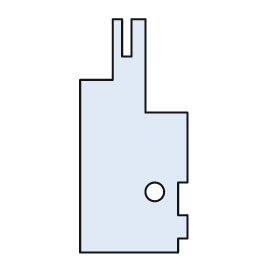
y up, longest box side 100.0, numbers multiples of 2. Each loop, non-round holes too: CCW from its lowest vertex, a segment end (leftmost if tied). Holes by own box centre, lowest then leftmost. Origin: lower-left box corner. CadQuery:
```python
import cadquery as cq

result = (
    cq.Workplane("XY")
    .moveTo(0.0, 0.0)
    .lineTo(42.0, 0.0)
    .lineTo(42.0, 6.0)
    .lineTo(46.0, 6.0)
    .lineTo(46.0, 16.0)
    .lineTo(42.0, 16.0)
    .lineTo(42.0, 30.0)
    .lineTo(46.0, 30.0)
    .lineTo(46.0, 60.0)
    .lineTo(28.0, 60.0)
    .lineTo(28.0, 100.0)
    .lineTo(22.0, 100.0)
    .lineTo(22.0, 84.0)
    .lineTo(18.0, 84.0)
    .lineTo(18.0, 100.0)
    .lineTo(14.0, 100.0)
    .lineTo(14.0, 74.0)
    .lineTo(0.0, 74.0)
    .close()
    .moveTo(32.0, 26.0)
    .circle(4.0)
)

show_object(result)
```